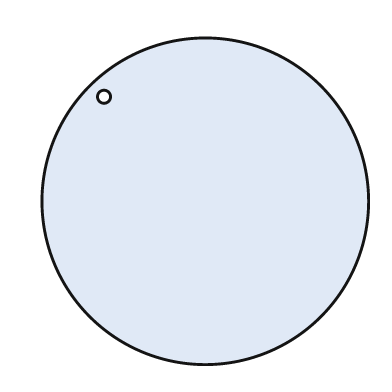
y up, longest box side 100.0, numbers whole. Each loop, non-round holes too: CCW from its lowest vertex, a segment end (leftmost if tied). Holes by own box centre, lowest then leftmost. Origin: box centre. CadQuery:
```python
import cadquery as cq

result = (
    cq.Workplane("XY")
    .moveTo(0.0, 0.0)
    .circle(50.0)
    .moveTo(-31.0, 32.0)
    .circle(2.0)
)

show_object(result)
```